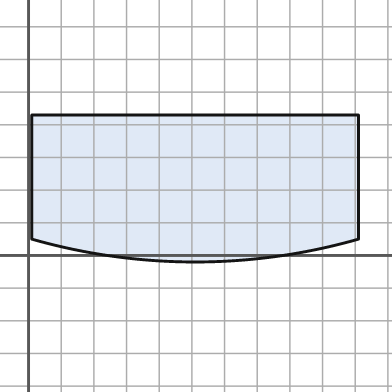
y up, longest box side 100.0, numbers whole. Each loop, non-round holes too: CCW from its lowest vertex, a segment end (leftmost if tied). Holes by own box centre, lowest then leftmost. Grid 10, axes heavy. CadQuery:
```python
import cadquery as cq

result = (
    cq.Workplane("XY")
    .moveTo(1.0, 5.0)
    .threePointArc((51.0, -2.0), (101.0, 5.0))
    .lineTo(101.0, 43.0)
    .lineTo(1.0, 43.0)
    .close()
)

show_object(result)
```